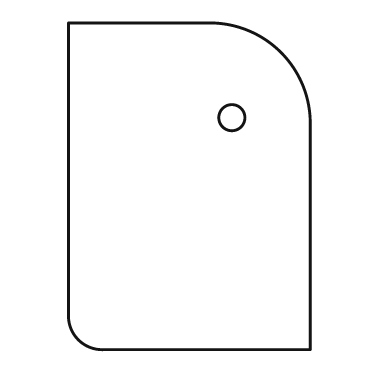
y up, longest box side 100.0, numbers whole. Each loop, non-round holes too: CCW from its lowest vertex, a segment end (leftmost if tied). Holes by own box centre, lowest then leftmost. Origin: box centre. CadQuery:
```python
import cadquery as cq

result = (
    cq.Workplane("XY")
    .moveTo(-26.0, -50.0)
    .lineTo(37.0, -50.0)
    .lineTo(37.0, 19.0)
    .threePointArc((28.0, 41.0), (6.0, 50.0))
    .lineTo(-37.0, 50.0)
    .lineTo(-37.0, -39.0)
    .threePointArc((-34.0, -47.0), (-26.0, -50.0))
    .close()
    .moveTo(13.0, 21.0)
    .circle(4.0)
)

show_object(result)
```